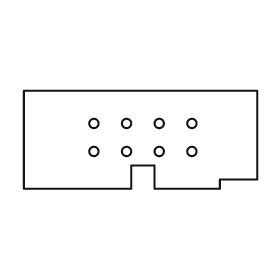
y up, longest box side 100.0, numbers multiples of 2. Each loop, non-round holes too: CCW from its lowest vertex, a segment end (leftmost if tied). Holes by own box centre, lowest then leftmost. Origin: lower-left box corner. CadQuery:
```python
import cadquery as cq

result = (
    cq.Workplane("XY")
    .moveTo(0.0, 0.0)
    .lineTo(46.0, 0.0)
    .lineTo(46.0, 10.0)
    .lineTo(56.0, 10.0)
    .lineTo(56.0, 0.0)
    .lineTo(84.0, 0.0)
    .lineTo(84.0, 4.0)
    .lineTo(100.0, 4.0)
    .lineTo(100.0, 42.0)
    .lineTo(0.0, 42.0)
    .close()
    .moveTo(30.0, 16.0)
    .circle(2.0)
    .moveTo(44.0, 16.0)
    .circle(2.0)
    .moveTo(58.0, 16.0)
    .circle(2.0)
    .moveTo(72.0, 16.0)
    .circle(2.0)
    .moveTo(30.0, 28.0)
    .circle(2.0)
    .moveTo(44.0, 28.0)
    .circle(2.0)
    .moveTo(58.0, 28.0)
    .circle(2.0)
    .moveTo(72.0, 28.0)
    .circle(2.0)
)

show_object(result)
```